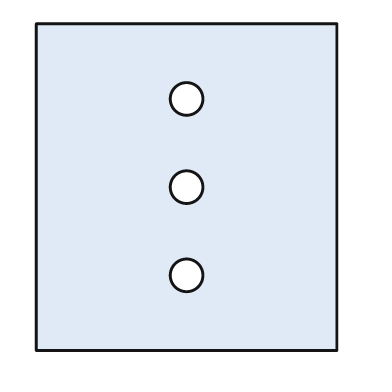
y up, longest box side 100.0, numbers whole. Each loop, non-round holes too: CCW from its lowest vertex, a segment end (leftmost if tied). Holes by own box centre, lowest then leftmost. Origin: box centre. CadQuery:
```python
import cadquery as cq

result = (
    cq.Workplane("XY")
    .moveTo(-46.0, -50.0)
    .lineTo(46.0, -50.0)
    .lineTo(46.0, 50.0)
    .lineTo(-46.0, 50.0)
    .close()
    .moveTo(0.0, -27.0)
    .circle(5.0)
    .moveTo(0.0, 0.0)
    .circle(5.0)
    .moveTo(0.0, 27.0)
    .circle(5.0)
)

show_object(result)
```